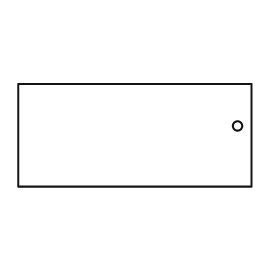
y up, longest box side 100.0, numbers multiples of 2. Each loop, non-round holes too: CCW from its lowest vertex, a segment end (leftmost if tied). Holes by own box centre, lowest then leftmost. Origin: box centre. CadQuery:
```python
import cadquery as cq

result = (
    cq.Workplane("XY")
    .moveTo(-50.0, -22.0)
    .lineTo(50.0, -22.0)
    .lineTo(50.0, 22.0)
    .lineTo(-50.0, 22.0)
    .close()
    .moveTo(44.0, 4.0)
    .circle(2.0)
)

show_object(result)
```